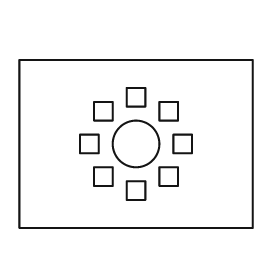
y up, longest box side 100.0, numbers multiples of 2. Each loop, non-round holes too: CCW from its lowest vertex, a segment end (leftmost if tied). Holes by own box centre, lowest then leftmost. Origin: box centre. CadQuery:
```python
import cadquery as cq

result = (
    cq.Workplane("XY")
    .moveTo(-50.0, -36.0)
    .lineTo(50.0, -36.0)
    .lineTo(50.0, 36.0)
    .lineTo(-50.0, 36.0)
    .close()
    .moveTo(-4.0, -24.0)
    .lineTo(4.0, -24.0)
    .lineTo(4.0, -16.0)
    .lineTo(-4.0, -16.0)
    .close()
    .moveTo(-18.0, -18.0)
    .lineTo(-10.0, -18.0)
    .lineTo(-10.0, -10.0)
    .lineTo(-18.0, -10.0)
    .close()
    .moveTo(10.0, -18.0)
    .lineTo(18.0, -18.0)
    .lineTo(18.0, -10.0)
    .lineTo(10.0, -10.0)
    .close()
    .moveTo(-24.0, -4.0)
    .lineTo(-16.0, -4.0)
    .lineTo(-16.0, 4.0)
    .lineTo(-24.0, 4.0)
    .close()
    .moveTo(0.0, 0.0)
    .circle(10.0)
    .moveTo(16.0, -4.0)
    .lineTo(24.0, -4.0)
    .lineTo(24.0, 4.0)
    .lineTo(16.0, 4.0)
    .close()
    .moveTo(-18.0, 10.0)
    .lineTo(-10.0, 10.0)
    .lineTo(-10.0, 18.0)
    .lineTo(-18.0, 18.0)
    .close()
    .moveTo(10.0, 10.0)
    .lineTo(18.0, 10.0)
    .lineTo(18.0, 18.0)
    .lineTo(10.0, 18.0)
    .close()
    .moveTo(-4.0, 16.0)
    .lineTo(4.0, 16.0)
    .lineTo(4.0, 24.0)
    .lineTo(-4.0, 24.0)
    .close()
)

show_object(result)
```